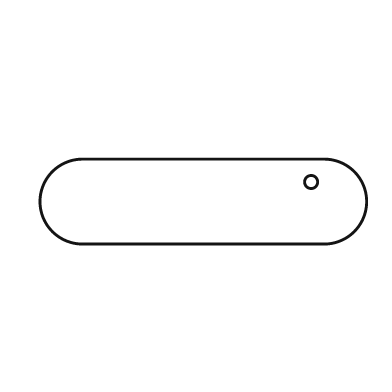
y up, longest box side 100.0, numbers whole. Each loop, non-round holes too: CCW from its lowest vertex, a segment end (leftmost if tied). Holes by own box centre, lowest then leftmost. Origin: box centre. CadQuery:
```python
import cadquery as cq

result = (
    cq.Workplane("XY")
    .moveTo(-37.0, -13.0)
    .lineTo(37.0, -13.0)
    .threePointArc((50.0, 0.0), (37.0, 13.0))
    .lineTo(-37.0, 13.0)
    .threePointArc((-50.0, 0.0), (-37.0, -13.0))
    .close()
    .moveTo(33.0, 6.0)
    .circle(2.0)
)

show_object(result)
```